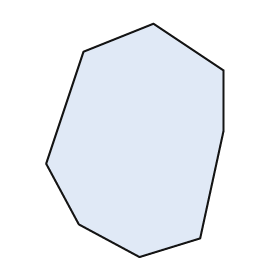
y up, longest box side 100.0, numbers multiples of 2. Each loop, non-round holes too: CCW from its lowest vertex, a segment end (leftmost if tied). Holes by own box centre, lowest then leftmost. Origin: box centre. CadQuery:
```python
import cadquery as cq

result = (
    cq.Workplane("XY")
    .moveTo(2.0, -50.0)
    .lineTo(28.0, -42.0)
    .lineTo(38.0, 4.0)
    .lineTo(38.0, 30.0)
    .lineTo(8.0, 50.0)
    .lineTo(-22.0, 38.0)
    .lineTo(-38.0, -10.0)
    .lineTo(-24.0, -36.0)
    .close()
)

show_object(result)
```